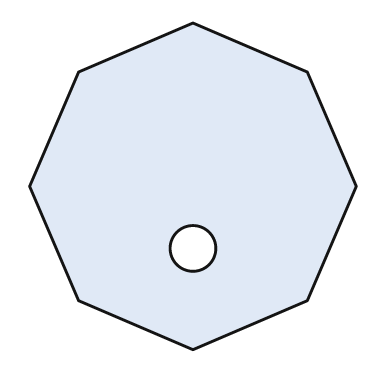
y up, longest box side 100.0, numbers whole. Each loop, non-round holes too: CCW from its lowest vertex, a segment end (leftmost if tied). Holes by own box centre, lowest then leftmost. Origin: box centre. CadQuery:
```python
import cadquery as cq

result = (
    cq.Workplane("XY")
    .moveTo(0.0, -50.0)
    .lineTo(35.0, -35.0)
    .lineTo(50.0, 0.0)
    .lineTo(35.0, 35.0)
    .lineTo(0.0, 50.0)
    .lineTo(-35.0, 35.0)
    .lineTo(-50.0, 0.0)
    .lineTo(-35.0, -35.0)
    .close()
    .moveTo(0.0, -19.0)
    .circle(7.0)
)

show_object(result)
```